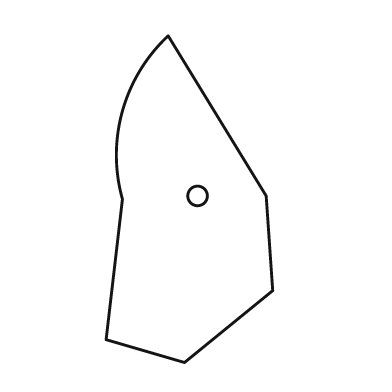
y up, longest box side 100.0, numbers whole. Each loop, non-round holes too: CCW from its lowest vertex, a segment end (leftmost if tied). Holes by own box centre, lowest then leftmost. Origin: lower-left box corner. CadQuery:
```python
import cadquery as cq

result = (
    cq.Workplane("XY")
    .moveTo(24.0, 0.0)
    .lineTo(51.0, 22.0)
    .lineTo(49.0, 51.0)
    .lineTo(19.0, 100.0)
    .threePointArc((5.0, 77.0), (5.0, 50.0))
    .lineTo(0.0, 7.0)
    .close()
    .moveTo(28.0, 51.0)
    .circle(3.0)
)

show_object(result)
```